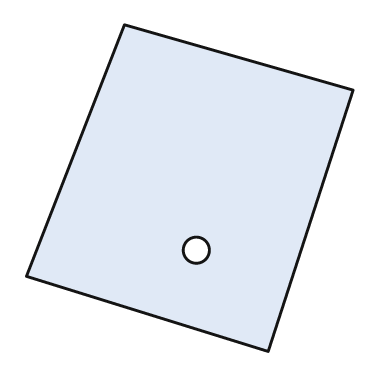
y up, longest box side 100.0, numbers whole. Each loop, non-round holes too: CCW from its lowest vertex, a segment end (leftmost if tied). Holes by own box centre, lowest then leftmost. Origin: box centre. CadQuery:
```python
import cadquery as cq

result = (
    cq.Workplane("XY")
    .moveTo(24.0, -50.0)
    .lineTo(50.0, 30.0)
    .lineTo(-20.0, 50.0)
    .lineTo(-50.0, -27.0)
    .close()
    .moveTo(2.0, -19.0)
    .circle(4.0)
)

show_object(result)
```